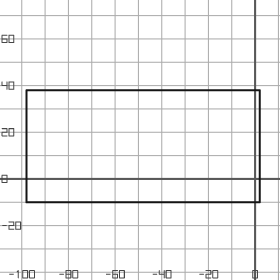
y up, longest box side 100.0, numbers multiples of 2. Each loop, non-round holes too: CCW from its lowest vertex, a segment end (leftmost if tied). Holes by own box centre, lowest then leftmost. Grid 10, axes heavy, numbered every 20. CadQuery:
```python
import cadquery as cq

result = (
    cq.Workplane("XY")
    .moveTo(-98.0, -10.0)
    .lineTo(2.0, -10.0)
    .lineTo(2.0, 38.0)
    .lineTo(-98.0, 38.0)
    .close()
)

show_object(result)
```